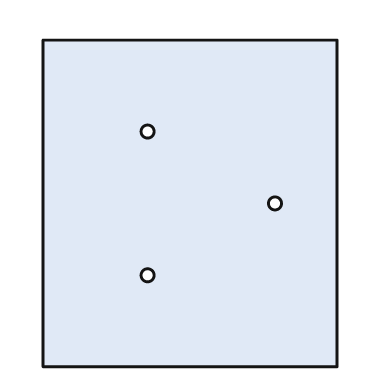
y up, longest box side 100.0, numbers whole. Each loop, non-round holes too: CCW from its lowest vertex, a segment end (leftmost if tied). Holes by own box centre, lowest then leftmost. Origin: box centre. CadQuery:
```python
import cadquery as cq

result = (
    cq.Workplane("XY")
    .moveTo(-45.0, -50.0)
    .lineTo(45.0, -50.0)
    .lineTo(45.0, 50.0)
    .lineTo(-45.0, 50.0)
    .close()
    .moveTo(-13.0, -22.0)
    .circle(2.0)
    .moveTo(26.0, 0.0)
    .circle(2.0)
    .moveTo(-13.0, 22.0)
    .circle(2.0)
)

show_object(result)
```